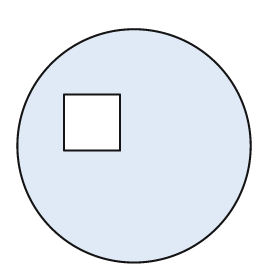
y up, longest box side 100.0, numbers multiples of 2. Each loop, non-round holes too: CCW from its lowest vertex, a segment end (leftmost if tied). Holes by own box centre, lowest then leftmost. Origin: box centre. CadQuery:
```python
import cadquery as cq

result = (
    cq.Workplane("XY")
    .moveTo(0.0, 0.0)
    .circle(50.0)
    .moveTo(-30.0, -2.0)
    .lineTo(-6.0, -2.0)
    .lineTo(-6.0, 22.0)
    .lineTo(-30.0, 22.0)
    .close()
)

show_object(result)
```